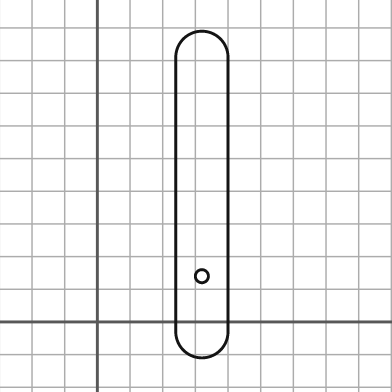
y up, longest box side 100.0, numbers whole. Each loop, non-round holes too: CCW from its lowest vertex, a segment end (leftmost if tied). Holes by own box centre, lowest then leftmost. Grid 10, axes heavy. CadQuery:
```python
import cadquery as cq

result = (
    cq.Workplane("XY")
    .moveTo(24.0, -3.0)
    .threePointArc((32.0, -11.0), (40.0, -3.0))
    .lineTo(40.0, 81.0)
    .threePointArc((32.0, 89.0), (24.0, 81.0))
    .close()
    .moveTo(32.0, 14.0)
    .circle(2.0)
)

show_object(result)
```